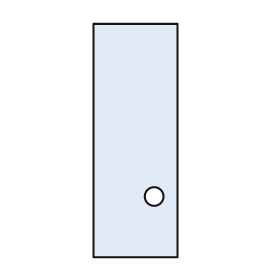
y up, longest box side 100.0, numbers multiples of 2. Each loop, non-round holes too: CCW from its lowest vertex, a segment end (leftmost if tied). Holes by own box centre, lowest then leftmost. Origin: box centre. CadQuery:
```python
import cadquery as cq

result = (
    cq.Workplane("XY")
    .moveTo(-18.0, -50.0)
    .lineTo(18.0, -50.0)
    .lineTo(18.0, 50.0)
    .lineTo(-18.0, 50.0)
    .close()
    .moveTo(8.0, -24.0)
    .circle(4.0)
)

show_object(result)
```